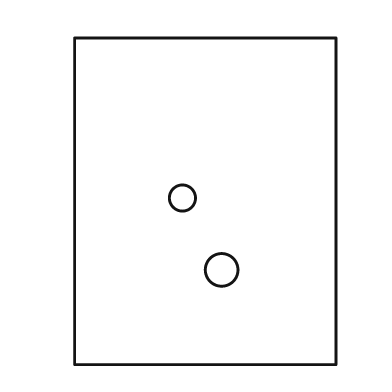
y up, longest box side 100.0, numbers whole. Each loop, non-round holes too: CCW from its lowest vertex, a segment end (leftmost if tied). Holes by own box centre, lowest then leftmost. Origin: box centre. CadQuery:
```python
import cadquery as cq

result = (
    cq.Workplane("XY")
    .moveTo(-40.0, -50.0)
    .lineTo(40.0, -50.0)
    .lineTo(40.0, 50.0)
    .lineTo(-40.0, 50.0)
    .close()
    .moveTo(5.0, -21.0)
    .circle(5.0)
    .moveTo(-7.0, 1.0)
    .circle(4.0)
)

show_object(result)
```